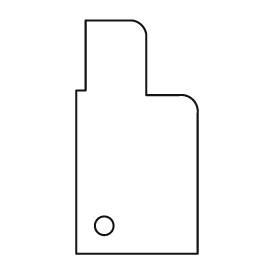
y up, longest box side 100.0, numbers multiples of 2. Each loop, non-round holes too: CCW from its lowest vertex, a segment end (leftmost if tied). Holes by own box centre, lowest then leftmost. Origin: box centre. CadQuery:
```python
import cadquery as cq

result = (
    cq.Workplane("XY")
    .moveTo(-26.0, -50.0)
    .lineTo(26.0, -50.0)
    .lineTo(26.0, 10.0)
    .threePointArc((24.0, 16.0), (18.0, 18.0))
    .lineTo(4.0, 18.0)
    .lineTo(4.0, 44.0)
    .threePointArc((2.0, 48.0), (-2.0, 50.0))
    .lineTo(-22.0, 50.0)
    .lineTo(-22.0, 20.0)
    .lineTo(-26.0, 20.0)
    .close()
    .moveTo(-14.0, -38.0)
    .circle(4.0)
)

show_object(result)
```